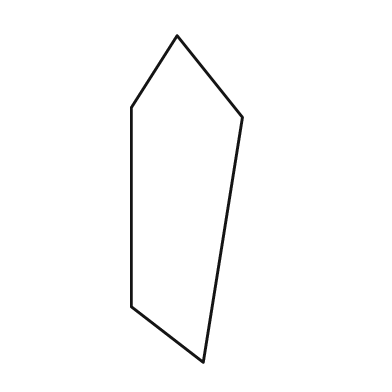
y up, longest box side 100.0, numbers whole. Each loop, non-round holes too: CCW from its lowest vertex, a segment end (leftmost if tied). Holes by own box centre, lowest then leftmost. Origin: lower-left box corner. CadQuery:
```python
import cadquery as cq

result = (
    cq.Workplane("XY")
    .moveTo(22.0, 0.0)
    .lineTo(34.0, 75.0)
    .lineTo(14.0, 100.0)
    .lineTo(0.0, 78.0)
    .lineTo(0.0, 17.0)
    .close()
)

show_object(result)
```